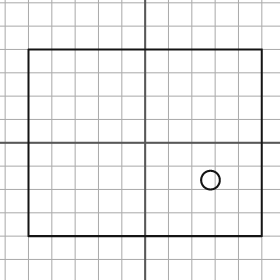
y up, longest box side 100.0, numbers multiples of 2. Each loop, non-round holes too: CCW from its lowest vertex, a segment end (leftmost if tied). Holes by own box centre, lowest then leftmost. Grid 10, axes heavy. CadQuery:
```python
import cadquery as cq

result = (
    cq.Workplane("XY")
    .moveTo(-50.0, -40.0)
    .lineTo(50.0, -40.0)
    .lineTo(50.0, 40.0)
    .lineTo(-50.0, 40.0)
    .close()
    .moveTo(28.0, -16.0)
    .circle(4.0)
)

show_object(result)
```